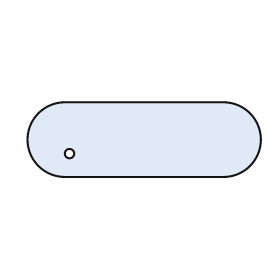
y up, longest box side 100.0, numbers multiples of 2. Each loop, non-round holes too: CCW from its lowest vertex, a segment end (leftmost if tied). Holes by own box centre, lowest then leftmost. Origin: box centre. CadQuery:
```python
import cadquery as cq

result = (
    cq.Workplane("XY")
    .moveTo(-34.0, -16.0)
    .lineTo(34.0, -16.0)
    .threePointArc((50.0, 0.0), (34.0, 16.0))
    .lineTo(-34.0, 16.0)
    .threePointArc((-50.0, 0.0), (-34.0, -16.0))
    .close()
    .moveTo(-32.0, -6.0)
    .circle(2.0)
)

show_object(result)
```